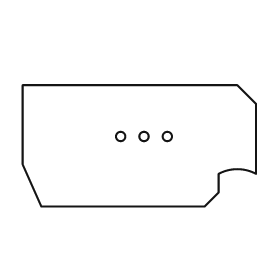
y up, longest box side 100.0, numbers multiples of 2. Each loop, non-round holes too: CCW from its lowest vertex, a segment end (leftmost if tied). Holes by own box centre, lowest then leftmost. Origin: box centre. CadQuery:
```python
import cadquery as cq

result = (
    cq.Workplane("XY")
    .moveTo(-42.0, -26.0)
    .lineTo(28.0, -26.0)
    .lineTo(34.0, -20.0)
    .lineTo(34.0, -12.0)
    .threePointArc((42.0, -10.0), (50.0, -12.0))
    .lineTo(50.0, 18.0)
    .lineTo(42.0, 26.0)
    .lineTo(-50.0, 26.0)
    .lineTo(-50.0, -8.0)
    .close()
    .moveTo(-8.0, 4.0)
    .circle(2.0)
    .moveTo(2.0, 4.0)
    .circle(2.0)
    .moveTo(12.0, 4.0)
    .circle(2.0)
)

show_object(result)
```